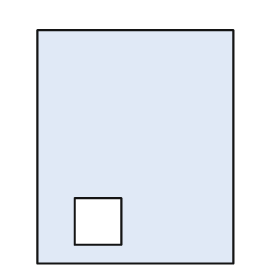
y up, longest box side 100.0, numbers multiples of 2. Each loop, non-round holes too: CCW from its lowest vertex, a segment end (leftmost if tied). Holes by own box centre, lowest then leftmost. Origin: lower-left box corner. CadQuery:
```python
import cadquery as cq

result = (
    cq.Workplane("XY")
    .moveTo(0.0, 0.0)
    .lineTo(84.0, 0.0)
    .lineTo(84.0, 100.0)
    .lineTo(0.0, 100.0)
    .close()
    .moveTo(16.0, 8.0)
    .lineTo(36.0, 8.0)
    .lineTo(36.0, 28.0)
    .lineTo(16.0, 28.0)
    .close()
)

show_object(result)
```